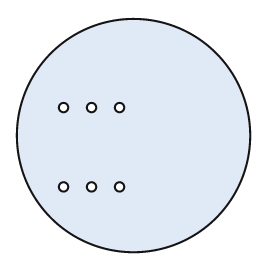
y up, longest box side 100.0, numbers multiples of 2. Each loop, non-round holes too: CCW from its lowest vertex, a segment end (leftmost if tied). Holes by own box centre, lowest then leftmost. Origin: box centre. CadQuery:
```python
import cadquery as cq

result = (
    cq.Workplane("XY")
    .moveTo(0.0, 0.0)
    .circle(50.0)
    .moveTo(-30.0, -22.0)
    .circle(2.0)
    .moveTo(-18.0, -22.0)
    .circle(2.0)
    .moveTo(-6.0, -22.0)
    .circle(2.0)
    .moveTo(-30.0, 12.0)
    .circle(2.0)
    .moveTo(-18.0, 12.0)
    .circle(2.0)
    .moveTo(-6.0, 12.0)
    .circle(2.0)
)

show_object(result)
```